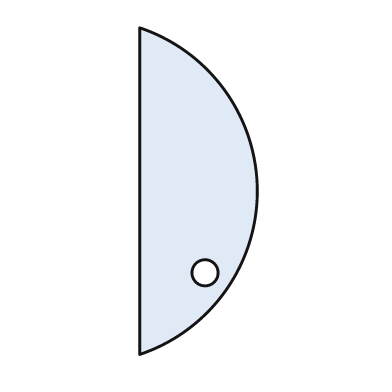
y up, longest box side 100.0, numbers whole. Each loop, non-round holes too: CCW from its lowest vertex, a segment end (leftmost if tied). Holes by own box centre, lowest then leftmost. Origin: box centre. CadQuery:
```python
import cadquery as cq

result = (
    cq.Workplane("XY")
    .moveTo(-18.0, -50.0)
    .threePointArc((18.0, 0.0), (-18.0, 50.0))
    .close()
    .moveTo(2.0, -25.0)
    .circle(4.0)
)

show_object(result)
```